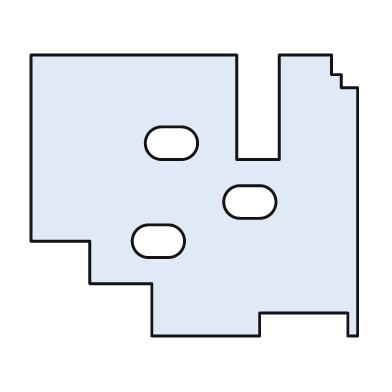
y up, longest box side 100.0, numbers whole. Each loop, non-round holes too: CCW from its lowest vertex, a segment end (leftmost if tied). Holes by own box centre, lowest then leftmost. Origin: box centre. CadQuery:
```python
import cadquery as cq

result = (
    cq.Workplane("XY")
    .moveTo(-13.0, -43.0)
    .lineTo(20.0, -43.0)
    .lineTo(20.0, -36.0)
    .lineTo(47.0, -36.0)
    .lineTo(47.0, -43.0)
    .lineTo(50.0, -43.0)
    .lineTo(50.0, 33.0)
    .lineTo(45.0, 33.0)
    .lineTo(45.0, 37.0)
    .lineTo(42.0, 37.0)
    .lineTo(42.0, 43.0)
    .lineTo(26.0, 43.0)
    .lineTo(26.0, 11.0)
    .lineTo(13.0, 11.0)
    .lineTo(13.0, 43.0)
    .lineTo(-50.0, 43.0)
    .lineTo(-50.0, -14.0)
    .lineTo(-32.0, -14.0)
    .lineTo(-32.0, -27.0)
    .lineTo(-13.0, -27.0)
    .close()
    .moveTo(-14.0, -19.0)
    .lineTo(-8.0, -19.0)
    .threePointArc((-3.0, -14.0), (-8.0, -9.0))
    .lineTo(-14.0, -9.0)
    .threePointArc((-19.0, -14.0), (-14.0, -19.0))
    .close()
    .moveTo(14.0, -7.0)
    .lineTo(20.0, -7.0)
    .threePointArc((25.0, -2.0), (20.0, 3.0))
    .lineTo(14.0, 3.0)
    .threePointArc((9.0, -2.0), (14.0, -7.0))
    .close()
    .moveTo(-10.0, 11.0)
    .lineTo(-4.0, 11.0)
    .threePointArc((1.0, 16.0), (-4.0, 21.0))
    .lineTo(-10.0, 21.0)
    .threePointArc((-15.0, 16.0), (-10.0, 11.0))
    .close()
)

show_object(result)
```